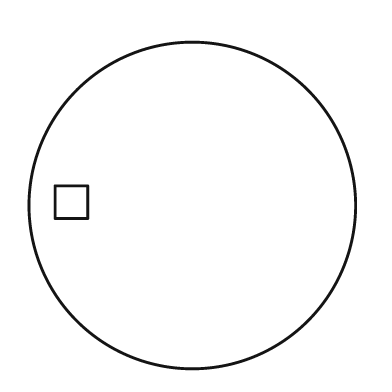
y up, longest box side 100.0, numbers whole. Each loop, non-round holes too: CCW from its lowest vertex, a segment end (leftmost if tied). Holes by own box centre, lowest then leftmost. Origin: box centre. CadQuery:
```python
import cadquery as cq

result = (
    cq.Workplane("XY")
    .moveTo(0.0, 0.0)
    .circle(50.0)
    .moveTo(-42.0, -4.0)
    .lineTo(-32.0, -4.0)
    .lineTo(-32.0, 6.0)
    .lineTo(-42.0, 6.0)
    .close()
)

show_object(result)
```